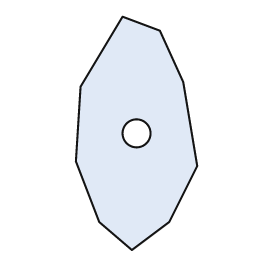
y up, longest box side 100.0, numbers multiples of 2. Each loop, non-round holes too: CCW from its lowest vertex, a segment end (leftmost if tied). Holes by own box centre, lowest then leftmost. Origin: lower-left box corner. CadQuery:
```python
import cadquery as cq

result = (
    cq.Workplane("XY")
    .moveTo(24.0, 0.0)
    .lineTo(40.0, 12.0)
    .lineTo(52.0, 36.0)
    .lineTo(46.0, 72.0)
    .lineTo(36.0, 94.0)
    .lineTo(20.0, 100.0)
    .lineTo(2.0, 70.0)
    .lineTo(0.0, 38.0)
    .lineTo(10.0, 12.0)
    .close()
    .moveTo(26.0, 50.0)
    .circle(6.0)
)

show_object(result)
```